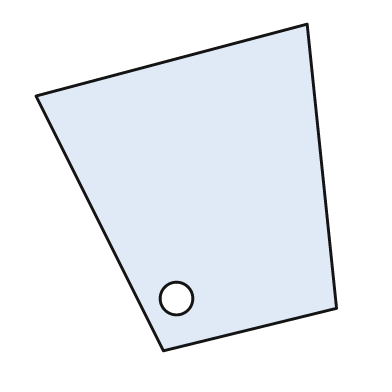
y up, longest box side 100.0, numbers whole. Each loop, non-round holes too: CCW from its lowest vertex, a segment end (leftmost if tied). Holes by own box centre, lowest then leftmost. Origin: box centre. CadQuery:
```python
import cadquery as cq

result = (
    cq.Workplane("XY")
    .moveTo(-7.0, -50.0)
    .lineTo(46.0, -37.0)
    .lineTo(37.0, 50.0)
    .lineTo(-46.0, 28.0)
    .close()
    .moveTo(-3.0, -34.0)
    .circle(5.0)
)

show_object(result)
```